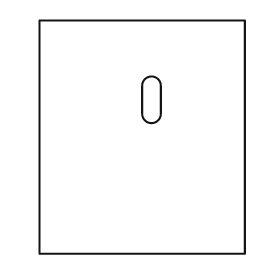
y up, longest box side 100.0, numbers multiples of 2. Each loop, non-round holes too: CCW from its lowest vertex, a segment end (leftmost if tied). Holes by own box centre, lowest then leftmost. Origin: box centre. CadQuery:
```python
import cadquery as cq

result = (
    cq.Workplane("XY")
    .moveTo(-44.0, -50.0)
    .lineTo(44.0, -50.0)
    .lineTo(44.0, 50.0)
    .lineTo(-44.0, 50.0)
    .close()
    .moveTo(0.0, 10.0)
    .threePointArc((4.0, 6.0), (8.0, 10.0))
    .lineTo(8.0, 22.0)
    .threePointArc((4.0, 26.0), (0.0, 22.0))
    .close()
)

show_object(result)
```